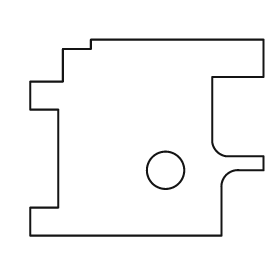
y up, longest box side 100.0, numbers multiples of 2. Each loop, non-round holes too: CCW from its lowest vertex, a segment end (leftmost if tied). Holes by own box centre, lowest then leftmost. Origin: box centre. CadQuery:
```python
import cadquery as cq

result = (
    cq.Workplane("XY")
    .moveTo(-50.0, -42.0)
    .lineTo(32.0, -42.0)
    .lineTo(32.0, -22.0)
    .threePointArc((34.0, -16.0), (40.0, -14.0))
    .lineTo(50.0, -14.0)
    .lineTo(50.0, -8.0)
    .lineTo(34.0, -8.0)
    .threePointArc((30.0, -6.0), (28.0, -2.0))
    .lineTo(28.0, 26.0)
    .lineTo(50.0, 26.0)
    .lineTo(50.0, 42.0)
    .lineTo(-24.0, 42.0)
    .lineTo(-24.0, 38.0)
    .lineTo(-36.0, 38.0)
    .lineTo(-36.0, 24.0)
    .lineTo(-50.0, 24.0)
    .lineTo(-50.0, 12.0)
    .lineTo(-38.0, 12.0)
    .lineTo(-38.0, -30.0)
    .lineTo(-50.0, -30.0)
    .close()
    .moveTo(8.0, -14.0)
    .circle(8.0)
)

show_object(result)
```